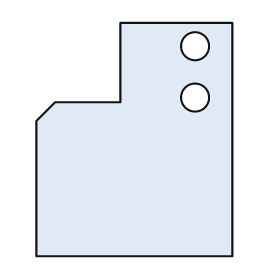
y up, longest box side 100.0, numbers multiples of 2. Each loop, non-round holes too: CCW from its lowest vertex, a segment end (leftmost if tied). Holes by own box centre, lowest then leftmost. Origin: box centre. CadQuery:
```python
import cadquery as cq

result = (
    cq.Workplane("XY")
    .moveTo(-42.0, -50.0)
    .lineTo(42.0, -50.0)
    .lineTo(42.0, 50.0)
    .lineTo(-6.0, 50.0)
    .lineTo(-6.0, 16.0)
    .lineTo(-34.0, 16.0)
    .lineTo(-42.0, 8.0)
    .close()
    .moveTo(26.0, 18.0)
    .circle(6.0)
    .moveTo(26.0, 40.0)
    .circle(6.0)
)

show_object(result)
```